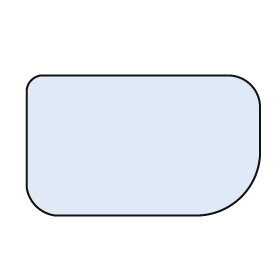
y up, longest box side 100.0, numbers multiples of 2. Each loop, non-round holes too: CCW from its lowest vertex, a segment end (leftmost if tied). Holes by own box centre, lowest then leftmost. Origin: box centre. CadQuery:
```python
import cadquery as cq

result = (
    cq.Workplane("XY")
    .moveTo(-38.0, -30.0)
    .lineTo(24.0, -30.0)
    .threePointArc((42.0, -22.0), (50.0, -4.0))
    .lineTo(50.0, 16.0)
    .threePointArc((46.0, 26.0), (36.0, 30.0))
    .lineTo(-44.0, 30.0)
    .threePointArc((-48.0, 28.0), (-50.0, 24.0))
    .lineTo(-50.0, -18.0)
    .threePointArc((-46.0, -26.0), (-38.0, -30.0))
    .close()
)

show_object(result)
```